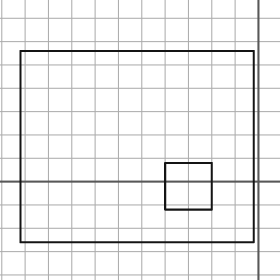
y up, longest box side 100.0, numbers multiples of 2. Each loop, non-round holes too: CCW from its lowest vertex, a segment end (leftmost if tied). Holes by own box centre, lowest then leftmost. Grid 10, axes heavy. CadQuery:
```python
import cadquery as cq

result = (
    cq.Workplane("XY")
    .moveTo(-102.0, -26.0)
    .lineTo(-2.0, -26.0)
    .lineTo(-2.0, 56.0)
    .lineTo(-102.0, 56.0)
    .close()
    .moveTo(-40.0, -12.0)
    .lineTo(-20.0, -12.0)
    .lineTo(-20.0, 8.0)
    .lineTo(-40.0, 8.0)
    .close()
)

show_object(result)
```